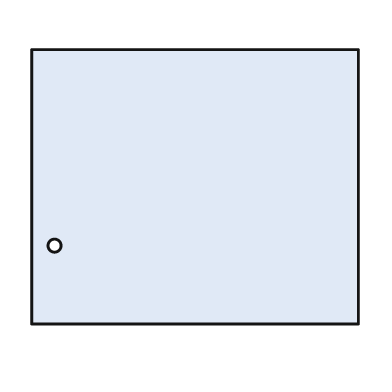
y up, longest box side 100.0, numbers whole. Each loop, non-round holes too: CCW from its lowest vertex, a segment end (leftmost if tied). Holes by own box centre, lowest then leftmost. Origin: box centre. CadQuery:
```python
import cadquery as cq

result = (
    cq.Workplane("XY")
    .moveTo(-50.0, -42.0)
    .lineTo(50.0, -42.0)
    .lineTo(50.0, 42.0)
    .lineTo(-50.0, 42.0)
    .close()
    .moveTo(-43.0, -18.0)
    .circle(2.0)
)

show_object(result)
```